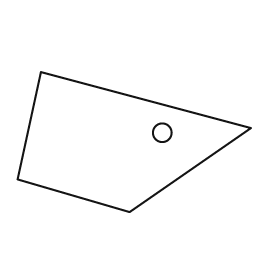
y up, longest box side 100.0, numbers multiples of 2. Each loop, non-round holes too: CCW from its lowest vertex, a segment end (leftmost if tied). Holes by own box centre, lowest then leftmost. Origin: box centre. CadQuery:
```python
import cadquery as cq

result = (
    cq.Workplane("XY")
    .moveTo(-2.0, -30.0)
    .lineTo(50.0, 6.0)
    .lineTo(-40.0, 30.0)
    .lineTo(-50.0, -16.0)
    .close()
    .moveTo(12.0, 4.0)
    .circle(4.0)
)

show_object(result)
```